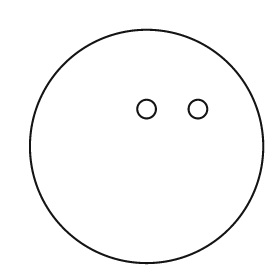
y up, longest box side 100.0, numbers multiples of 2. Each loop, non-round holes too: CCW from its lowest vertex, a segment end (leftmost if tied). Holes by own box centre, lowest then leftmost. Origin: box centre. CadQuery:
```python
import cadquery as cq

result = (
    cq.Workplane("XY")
    .moveTo(0.0, 0.0)
    .circle(50.0)
    .moveTo(0.0, 16.0)
    .circle(4.0)
    .moveTo(22.0, 16.0)
    .circle(4.0)
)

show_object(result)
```